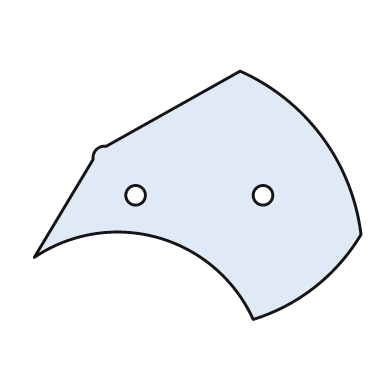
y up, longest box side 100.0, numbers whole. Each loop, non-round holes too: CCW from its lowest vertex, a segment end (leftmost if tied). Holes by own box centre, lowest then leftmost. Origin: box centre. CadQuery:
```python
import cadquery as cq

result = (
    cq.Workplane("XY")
    .moveTo(17.0, -38.0)
    .threePointArc((36.0, -28.0), (50.0, -12.0))
    .threePointArc((38.0, 18.0), (13.0, 38.0))
    .lineTo(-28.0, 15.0)
    .threePointArc((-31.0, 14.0), (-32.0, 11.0))
    .lineTo(-50.0, -19.0)
    .threePointArc((-12.0, -13.0), (17.0, -38.0))
    .close()
    .moveTo(-19.0, 0.0)
    .circle(3.0)
    .moveTo(20.0, 0.0)
    .circle(3.0)
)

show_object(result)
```